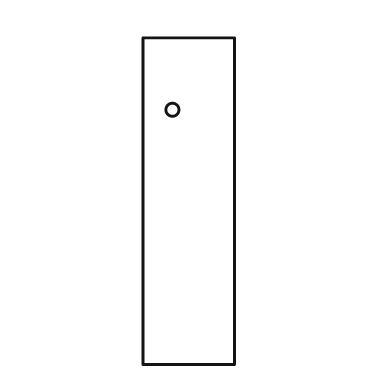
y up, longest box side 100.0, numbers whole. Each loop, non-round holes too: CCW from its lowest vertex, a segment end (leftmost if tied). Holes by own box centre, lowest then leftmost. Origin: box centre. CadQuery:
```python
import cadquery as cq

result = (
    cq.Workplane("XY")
    .moveTo(-14.0, -50.0)
    .lineTo(14.0, -50.0)
    .lineTo(14.0, 50.0)
    .lineTo(-14.0, 50.0)
    .close()
    .moveTo(-5.0, 28.0)
    .circle(2.0)
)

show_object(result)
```